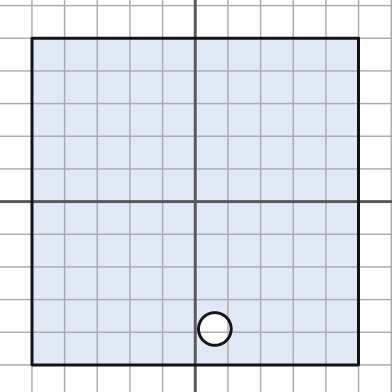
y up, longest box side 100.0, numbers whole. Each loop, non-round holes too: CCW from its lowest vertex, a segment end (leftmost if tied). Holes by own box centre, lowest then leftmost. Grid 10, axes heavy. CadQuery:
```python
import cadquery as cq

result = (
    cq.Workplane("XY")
    .moveTo(-50.0, -50.0)
    .lineTo(50.0, -50.0)
    .lineTo(50.0, 50.0)
    .lineTo(-50.0, 50.0)
    .close()
    .moveTo(6.0, -39.0)
    .circle(5.0)
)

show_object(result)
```